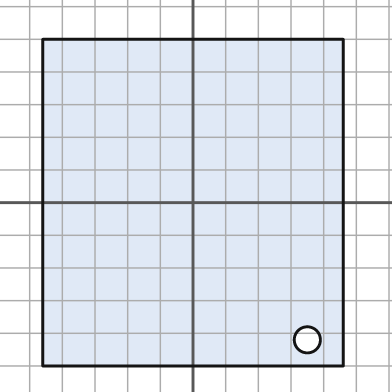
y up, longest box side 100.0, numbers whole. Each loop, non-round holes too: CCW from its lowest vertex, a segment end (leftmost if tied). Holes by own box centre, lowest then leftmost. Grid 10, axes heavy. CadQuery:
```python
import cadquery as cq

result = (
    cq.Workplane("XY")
    .moveTo(-46.0, -50.0)
    .lineTo(46.0, -50.0)
    .lineTo(46.0, 50.0)
    .lineTo(-46.0, 50.0)
    .close()
    .moveTo(35.0, -42.0)
    .circle(4.0)
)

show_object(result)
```